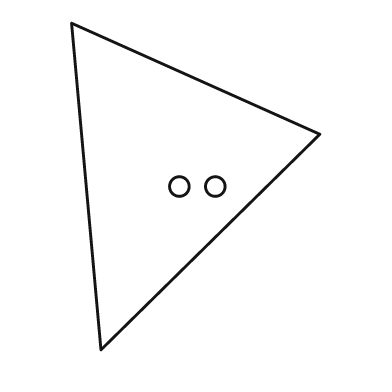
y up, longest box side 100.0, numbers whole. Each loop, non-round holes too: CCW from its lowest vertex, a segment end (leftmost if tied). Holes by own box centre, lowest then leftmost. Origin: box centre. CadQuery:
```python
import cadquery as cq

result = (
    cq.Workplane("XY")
    .moveTo(-29.0, -50.0)
    .lineTo(38.0, 16.0)
    .lineTo(-38.0, 50.0)
    .close()
    .moveTo(-5.0, 0.0)
    .circle(3.0)
    .moveTo(6.0, 0.0)
    .circle(3.0)
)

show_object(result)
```